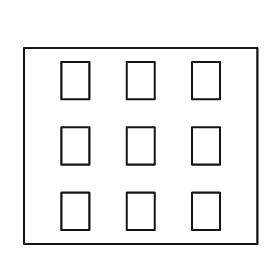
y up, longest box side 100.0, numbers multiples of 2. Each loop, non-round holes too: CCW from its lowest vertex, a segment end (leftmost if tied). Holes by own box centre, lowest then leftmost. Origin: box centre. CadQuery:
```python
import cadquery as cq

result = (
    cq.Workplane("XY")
    .moveTo(-50.0, -42.0)
    .lineTo(50.0, -42.0)
    .lineTo(50.0, 42.0)
    .lineTo(-50.0, 42.0)
    .close()
    .moveTo(-34.0, -36.0)
    .lineTo(-22.0, -36.0)
    .lineTo(-22.0, -20.0)
    .lineTo(-34.0, -20.0)
    .close()
    .moveTo(-6.0, -36.0)
    .lineTo(6.0, -36.0)
    .lineTo(6.0, -20.0)
    .lineTo(-6.0, -20.0)
    .close()
    .moveTo(22.0, -36.0)
    .lineTo(34.0, -36.0)
    .lineTo(34.0, -20.0)
    .lineTo(22.0, -20.0)
    .close()
    .moveTo(-34.0, -8.0)
    .lineTo(-22.0, -8.0)
    .lineTo(-22.0, 8.0)
    .lineTo(-34.0, 8.0)
    .close()
    .moveTo(-6.0, -8.0)
    .lineTo(6.0, -8.0)
    .lineTo(6.0, 8.0)
    .lineTo(-6.0, 8.0)
    .close()
    .moveTo(22.0, -8.0)
    .lineTo(34.0, -8.0)
    .lineTo(34.0, 8.0)
    .lineTo(22.0, 8.0)
    .close()
    .moveTo(-34.0, 20.0)
    .lineTo(-22.0, 20.0)
    .lineTo(-22.0, 36.0)
    .lineTo(-34.0, 36.0)
    .close()
    .moveTo(-6.0, 20.0)
    .lineTo(6.0, 20.0)
    .lineTo(6.0, 36.0)
    .lineTo(-6.0, 36.0)
    .close()
    .moveTo(22.0, 20.0)
    .lineTo(34.0, 20.0)
    .lineTo(34.0, 36.0)
    .lineTo(22.0, 36.0)
    .close()
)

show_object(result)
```